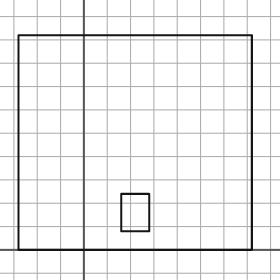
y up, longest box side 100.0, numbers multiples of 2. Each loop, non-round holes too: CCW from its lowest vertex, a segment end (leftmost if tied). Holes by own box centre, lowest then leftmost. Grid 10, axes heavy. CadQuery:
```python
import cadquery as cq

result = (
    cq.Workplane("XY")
    .moveTo(-28.0, 0.0)
    .lineTo(72.0, 0.0)
    .lineTo(72.0, 92.0)
    .lineTo(-28.0, 92.0)
    .close()
    .moveTo(16.0, 8.0)
    .lineTo(28.0, 8.0)
    .lineTo(28.0, 24.0)
    .lineTo(16.0, 24.0)
    .close()
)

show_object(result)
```